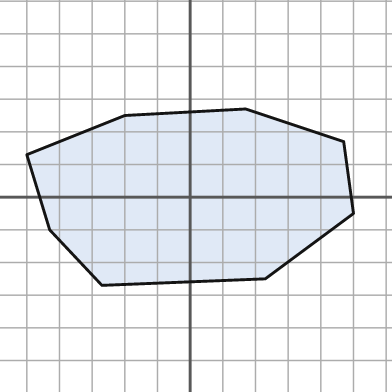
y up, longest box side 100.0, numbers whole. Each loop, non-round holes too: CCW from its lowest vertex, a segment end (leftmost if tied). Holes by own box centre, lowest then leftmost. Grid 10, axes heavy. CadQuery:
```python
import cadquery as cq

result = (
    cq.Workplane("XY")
    .moveTo(-27.0, -27.0)
    .lineTo(23.0, -25.0)
    .lineTo(50.0, -5.0)
    .lineTo(47.0, 17.0)
    .lineTo(17.0, 27.0)
    .lineTo(-20.0, 25.0)
    .lineTo(-50.0, 13.0)
    .lineTo(-43.0, -10.0)
    .close()
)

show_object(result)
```